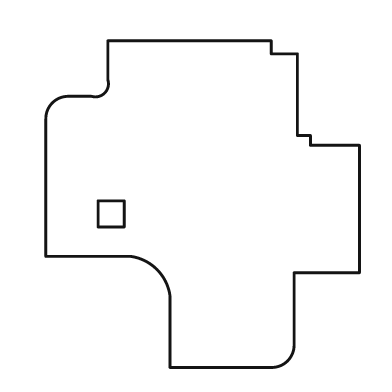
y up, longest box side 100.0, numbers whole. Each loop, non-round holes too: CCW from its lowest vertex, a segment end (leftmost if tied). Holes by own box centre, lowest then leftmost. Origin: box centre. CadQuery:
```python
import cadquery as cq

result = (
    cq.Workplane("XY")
    .moveTo(-10.0, -50.0)
    .lineTo(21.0, -50.0)
    .threePointArc((26.0, -48.0), (28.0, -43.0))
    .lineTo(28.0, -21.0)
    .lineTo(48.0, -21.0)
    .lineTo(48.0, 18.0)
    .lineTo(33.0, 18.0)
    .lineTo(33.0, 21.0)
    .lineTo(29.0, 21.0)
    .lineTo(29.0, 46.0)
    .lineTo(21.0, 46.0)
    .lineTo(21.0, 50.0)
    .lineTo(-29.0, 50.0)
    .lineTo(-29.0, 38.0)
    .threePointArc((-30.0, 34.0), (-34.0, 33.0))
    .lineTo(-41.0, 33.0)
    .threePointArc((-46.0, 31.0), (-48.0, 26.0))
    .lineTo(-48.0, -16.0)
    .lineTo(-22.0, -16.0)
    .threePointArc((-14.0, -20.0), (-10.0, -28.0))
    .close()
    .moveTo(-32.0, -7.0)
    .lineTo(-24.0, -7.0)
    .lineTo(-24.0, 1.0)
    .lineTo(-32.0, 1.0)
    .close()
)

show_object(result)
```